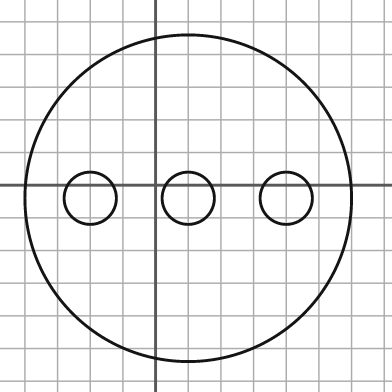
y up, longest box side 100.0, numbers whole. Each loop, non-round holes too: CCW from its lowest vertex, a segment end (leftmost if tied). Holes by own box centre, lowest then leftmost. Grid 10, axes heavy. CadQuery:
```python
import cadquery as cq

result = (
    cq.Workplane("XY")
    .moveTo(10.0, -4.0)
    .circle(50.0)
    .moveTo(-20.0, -4.0)
    .circle(8.0)
    .moveTo(10.0, -4.0)
    .circle(8.0)
    .moveTo(40.0, -4.0)
    .circle(8.0)
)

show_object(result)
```